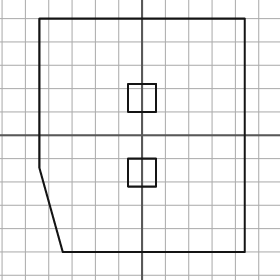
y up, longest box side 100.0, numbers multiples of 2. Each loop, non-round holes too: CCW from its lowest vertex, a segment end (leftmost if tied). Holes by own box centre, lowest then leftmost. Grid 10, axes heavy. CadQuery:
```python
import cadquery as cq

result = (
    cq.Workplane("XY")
    .moveTo(-34.0, -50.0)
    .lineTo(44.0, -50.0)
    .lineTo(44.0, 50.0)
    .lineTo(-44.0, 50.0)
    .lineTo(-44.0, -14.0)
    .close()
    .moveTo(-6.0, -22.0)
    .lineTo(6.0, -22.0)
    .lineTo(6.0, -10.0)
    .lineTo(-6.0, -10.0)
    .close()
    .moveTo(-6.0, 10.0)
    .lineTo(6.0, 10.0)
    .lineTo(6.0, 22.0)
    .lineTo(-6.0, 22.0)
    .close()
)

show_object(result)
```